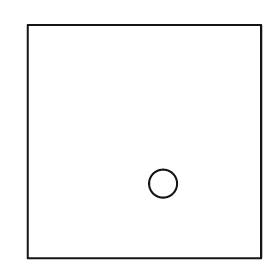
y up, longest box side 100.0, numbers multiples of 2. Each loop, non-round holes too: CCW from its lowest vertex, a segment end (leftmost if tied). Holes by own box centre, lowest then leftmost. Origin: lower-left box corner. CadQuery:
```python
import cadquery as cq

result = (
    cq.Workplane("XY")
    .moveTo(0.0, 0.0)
    .lineTo(100.0, 0.0)
    .lineTo(100.0, 100.0)
    .lineTo(0.0, 100.0)
    .close()
    .moveTo(58.0, 32.0)
    .circle(6.0)
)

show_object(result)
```